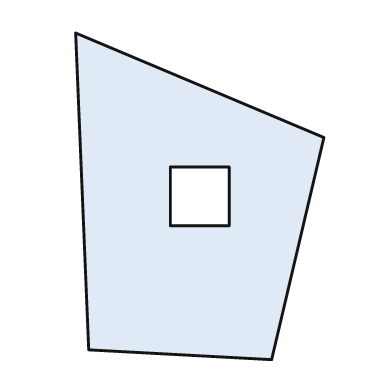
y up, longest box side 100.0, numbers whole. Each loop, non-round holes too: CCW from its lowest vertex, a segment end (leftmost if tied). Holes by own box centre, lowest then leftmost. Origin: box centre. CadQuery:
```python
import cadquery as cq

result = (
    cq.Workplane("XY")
    .moveTo(22.0, -50.0)
    .lineTo(38.0, 18.0)
    .lineTo(-38.0, 50.0)
    .lineTo(-34.0, -47.0)
    .close()
    .moveTo(-9.0, -9.0)
    .lineTo(9.0, -9.0)
    .lineTo(9.0, 9.0)
    .lineTo(-9.0, 9.0)
    .close()
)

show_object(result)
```